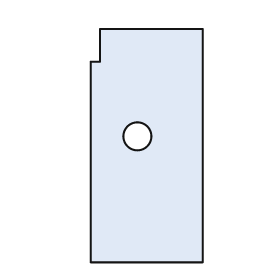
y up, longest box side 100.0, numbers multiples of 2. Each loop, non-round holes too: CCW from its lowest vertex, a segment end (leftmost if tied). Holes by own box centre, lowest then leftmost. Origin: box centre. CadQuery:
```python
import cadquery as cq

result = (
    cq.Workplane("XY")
    .moveTo(-24.0, -50.0)
    .lineTo(24.0, -50.0)
    .lineTo(24.0, 50.0)
    .lineTo(-20.0, 50.0)
    .lineTo(-20.0, 36.0)
    .lineTo(-24.0, 36.0)
    .close()
    .moveTo(-4.0, 4.0)
    .circle(6.0)
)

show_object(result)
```